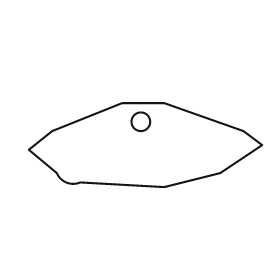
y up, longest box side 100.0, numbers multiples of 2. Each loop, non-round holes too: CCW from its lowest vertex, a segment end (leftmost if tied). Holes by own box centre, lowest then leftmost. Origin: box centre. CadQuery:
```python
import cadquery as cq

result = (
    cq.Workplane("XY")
    .moveTo(8.0, -18.0)
    .lineTo(32.0, -12.0)
    .lineTo(50.0, 0.0)
    .lineTo(42.0, 6.0)
    .lineTo(8.0, 18.0)
    .lineTo(-10.0, 18.0)
    .lineTo(-40.0, 6.0)
    .lineTo(-50.0, -2.0)
    .lineTo(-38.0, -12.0)
    .threePointArc((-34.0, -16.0), (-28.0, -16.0))
    .close()
    .moveTo(-2.0, 10.0)
    .circle(4.0)
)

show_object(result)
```